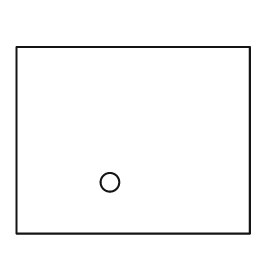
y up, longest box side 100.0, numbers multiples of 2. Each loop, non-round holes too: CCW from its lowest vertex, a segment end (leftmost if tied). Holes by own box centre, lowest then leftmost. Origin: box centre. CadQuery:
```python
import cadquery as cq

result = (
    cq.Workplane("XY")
    .moveTo(-50.0, -40.0)
    .lineTo(50.0, -40.0)
    .lineTo(50.0, 40.0)
    .lineTo(-50.0, 40.0)
    .close()
    .moveTo(-10.0, -18.0)
    .circle(4.0)
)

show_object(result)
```